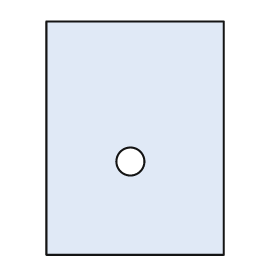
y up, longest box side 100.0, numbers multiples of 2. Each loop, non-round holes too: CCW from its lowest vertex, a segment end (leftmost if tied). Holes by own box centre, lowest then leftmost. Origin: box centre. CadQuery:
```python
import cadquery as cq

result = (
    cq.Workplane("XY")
    .moveTo(-38.0, -50.0)
    .lineTo(38.0, -50.0)
    .lineTo(38.0, 50.0)
    .lineTo(-38.0, 50.0)
    .close()
    .moveTo(-2.0, -10.0)
    .circle(6.0)
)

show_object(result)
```